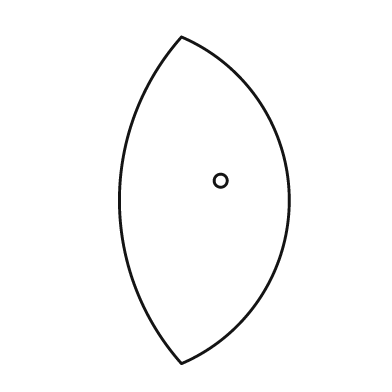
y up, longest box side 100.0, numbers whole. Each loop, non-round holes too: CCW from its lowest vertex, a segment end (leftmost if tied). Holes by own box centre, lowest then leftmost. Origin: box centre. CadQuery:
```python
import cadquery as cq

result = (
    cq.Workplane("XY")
    .moveTo(-7.0, -50.0)
    .threePointArc((26.0, 0.0), (-7.0, 50.0))
    .threePointArc((-26.0, 0.0), (-7.0, -50.0))
    .close()
    .moveTo(5.0, 6.0)
    .circle(2.0)
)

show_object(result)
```